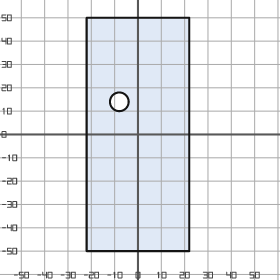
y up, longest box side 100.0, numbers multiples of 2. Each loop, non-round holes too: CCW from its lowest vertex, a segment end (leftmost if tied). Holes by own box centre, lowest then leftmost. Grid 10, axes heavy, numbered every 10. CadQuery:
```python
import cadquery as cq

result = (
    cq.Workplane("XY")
    .moveTo(-22.0, -50.0)
    .lineTo(22.0, -50.0)
    .lineTo(22.0, 50.0)
    .lineTo(-22.0, 50.0)
    .close()
    .moveTo(-8.0, 14.0)
    .circle(4.0)
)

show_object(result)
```